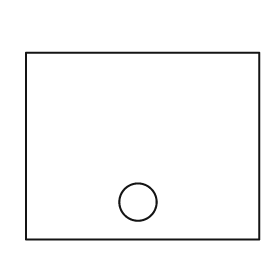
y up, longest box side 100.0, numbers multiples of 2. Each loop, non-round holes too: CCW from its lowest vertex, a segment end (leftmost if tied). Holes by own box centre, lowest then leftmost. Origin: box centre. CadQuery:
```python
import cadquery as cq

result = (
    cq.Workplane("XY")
    .moveTo(-50.0, -40.0)
    .lineTo(50.0, -40.0)
    .lineTo(50.0, 40.0)
    .lineTo(-50.0, 40.0)
    .close()
    .moveTo(-2.0, -24.0)
    .circle(8.0)
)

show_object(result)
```